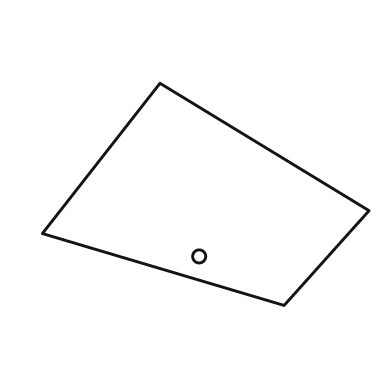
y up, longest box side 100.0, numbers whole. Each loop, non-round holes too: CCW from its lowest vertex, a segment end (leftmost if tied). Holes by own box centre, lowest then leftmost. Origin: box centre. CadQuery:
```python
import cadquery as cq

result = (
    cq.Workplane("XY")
    .moveTo(24.0, -34.0)
    .lineTo(50.0, -5.0)
    .lineTo(-14.0, 34.0)
    .lineTo(-50.0, -12.0)
    .close()
    .moveTo(-2.0, -19.0)
    .circle(2.0)
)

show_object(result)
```